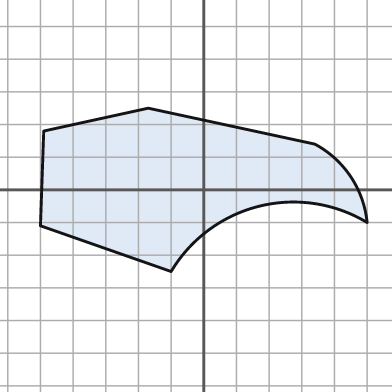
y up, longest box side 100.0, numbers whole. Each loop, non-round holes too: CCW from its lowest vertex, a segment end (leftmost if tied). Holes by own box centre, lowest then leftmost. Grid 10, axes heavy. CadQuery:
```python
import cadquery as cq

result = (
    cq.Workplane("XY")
    .moveTo(-10.0, -25.0)
    .threePointArc((17.0, -5.0), (50.0, -10.0))
    .threePointArc((45.0, 4.0), (34.0, 14.0))
    .lineTo(-17.0, 25.0)
    .lineTo(-49.0, 18.0)
    .lineTo(-50.0, -11.0)
    .close()
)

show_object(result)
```